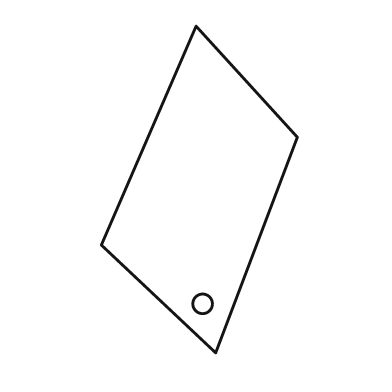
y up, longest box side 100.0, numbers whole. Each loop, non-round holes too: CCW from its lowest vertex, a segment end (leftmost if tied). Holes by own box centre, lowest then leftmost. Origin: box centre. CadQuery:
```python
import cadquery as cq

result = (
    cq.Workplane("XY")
    .moveTo(5.0, -50.0)
    .lineTo(30.0, 16.0)
    .lineTo(-1.0, 50.0)
    .lineTo(-30.0, -17.0)
    .close()
    .moveTo(1.0, -35.0)
    .circle(3.0)
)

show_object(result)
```